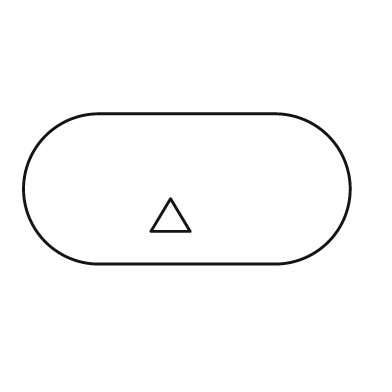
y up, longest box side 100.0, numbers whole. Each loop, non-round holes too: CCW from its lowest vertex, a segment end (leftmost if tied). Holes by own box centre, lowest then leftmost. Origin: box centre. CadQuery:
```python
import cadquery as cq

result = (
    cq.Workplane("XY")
    .moveTo(-27.0, -23.0)
    .lineTo(27.0, -23.0)
    .threePointArc((50.0, 0.0), (27.0, 23.0))
    .lineTo(-27.0, 23.0)
    .threePointArc((-50.0, 0.0), (-27.0, -23.0))
    .close()
    .moveTo(-11.0, -13.0)
    .lineTo(1.0, -13.0)
    .lineTo(-5.0, -3.0)
    .close()
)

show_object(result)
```